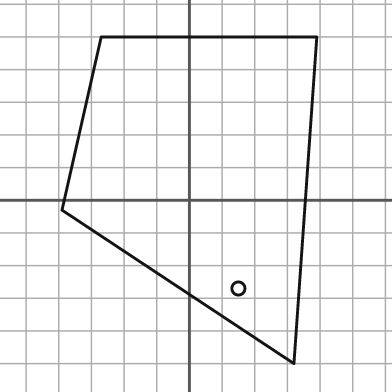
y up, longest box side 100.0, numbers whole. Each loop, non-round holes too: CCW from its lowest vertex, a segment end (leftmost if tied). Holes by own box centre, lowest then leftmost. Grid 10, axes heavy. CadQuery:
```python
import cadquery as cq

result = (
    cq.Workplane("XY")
    .moveTo(32.0, -50.0)
    .lineTo(39.0, 50.0)
    .lineTo(-27.0, 50.0)
    .lineTo(-39.0, -3.0)
    .close()
    .moveTo(15.0, -27.0)
    .circle(2.0)
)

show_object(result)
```